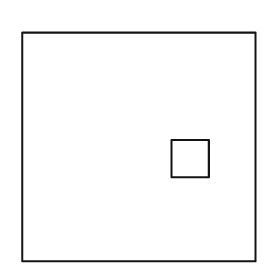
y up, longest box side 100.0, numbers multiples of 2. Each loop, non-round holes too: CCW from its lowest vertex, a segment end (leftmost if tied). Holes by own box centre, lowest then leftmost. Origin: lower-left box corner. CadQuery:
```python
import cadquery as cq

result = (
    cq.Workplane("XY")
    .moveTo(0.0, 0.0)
    .lineTo(100.0, 0.0)
    .lineTo(100.0, 98.0)
    .lineTo(0.0, 98.0)
    .close()
    .moveTo(64.0, 36.0)
    .lineTo(80.0, 36.0)
    .lineTo(80.0, 52.0)
    .lineTo(64.0, 52.0)
    .close()
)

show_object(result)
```